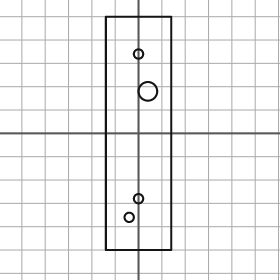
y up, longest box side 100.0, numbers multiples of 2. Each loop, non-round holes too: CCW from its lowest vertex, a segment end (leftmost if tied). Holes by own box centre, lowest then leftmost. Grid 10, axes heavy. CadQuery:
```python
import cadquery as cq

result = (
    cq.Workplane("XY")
    .moveTo(-14.0, -50.0)
    .lineTo(14.0, -50.0)
    .lineTo(14.0, 50.0)
    .lineTo(-14.0, 50.0)
    .close()
    .moveTo(-4.0, -36.0)
    .circle(2.0)
    .moveTo(0.0, -28.0)
    .circle(2.0)
    .moveTo(4.0, 18.0)
    .circle(4.0)
    .moveTo(0.0, 34.0)
    .circle(2.0)
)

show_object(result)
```